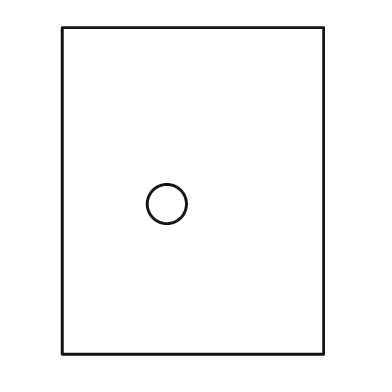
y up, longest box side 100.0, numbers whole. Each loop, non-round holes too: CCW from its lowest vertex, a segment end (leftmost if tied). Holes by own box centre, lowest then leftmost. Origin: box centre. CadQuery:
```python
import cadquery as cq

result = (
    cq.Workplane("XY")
    .moveTo(-40.0, -50.0)
    .lineTo(40.0, -50.0)
    .lineTo(40.0, 50.0)
    .lineTo(-40.0, 50.0)
    .close()
    .moveTo(-8.0, -4.0)
    .circle(6.0)
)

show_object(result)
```